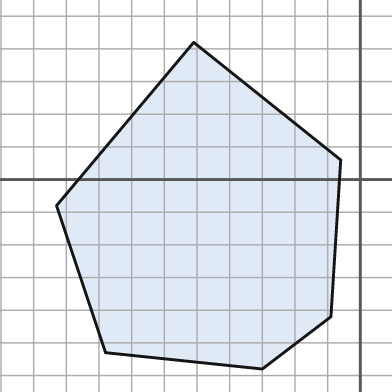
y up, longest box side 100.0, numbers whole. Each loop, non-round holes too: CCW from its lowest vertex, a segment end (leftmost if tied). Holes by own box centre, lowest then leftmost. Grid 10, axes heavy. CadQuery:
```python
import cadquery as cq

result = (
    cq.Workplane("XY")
    .moveTo(-30.0, -58.0)
    .lineTo(-9.0, -42.0)
    .lineTo(-6.0, 6.0)
    .lineTo(-51.0, 42.0)
    .lineTo(-93.0, -8.0)
    .lineTo(-78.0, -53.0)
    .close()
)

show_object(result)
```